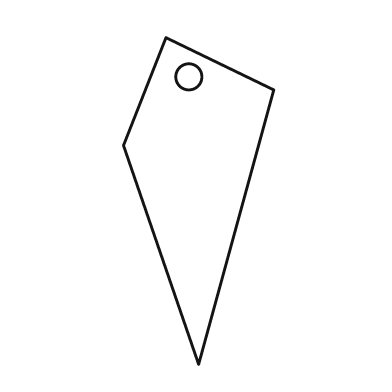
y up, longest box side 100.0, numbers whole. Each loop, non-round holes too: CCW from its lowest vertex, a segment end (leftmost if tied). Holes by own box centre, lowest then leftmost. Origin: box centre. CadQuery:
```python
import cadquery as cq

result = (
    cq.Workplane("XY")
    .moveTo(0.0, -50.0)
    .lineTo(23.0, 34.0)
    .lineTo(-10.0, 50.0)
    .lineTo(-23.0, 17.0)
    .close()
    .moveTo(-3.0, 38.0)
    .circle(4.0)
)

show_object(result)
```